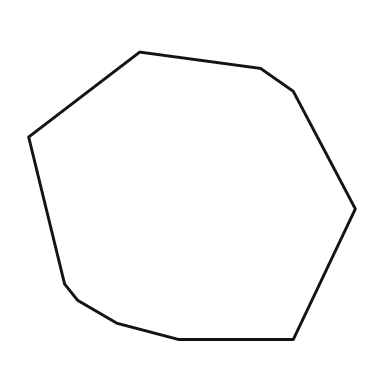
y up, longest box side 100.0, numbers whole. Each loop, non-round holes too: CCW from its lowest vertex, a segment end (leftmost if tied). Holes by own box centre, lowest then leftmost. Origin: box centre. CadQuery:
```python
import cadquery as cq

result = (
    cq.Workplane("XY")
    .moveTo(-4.0, -44.0)
    .lineTo(31.0, -44.0)
    .lineTo(50.0, -4.0)
    .lineTo(31.0, 32.0)
    .lineTo(21.0, 39.0)
    .lineTo(-16.0, 44.0)
    .lineTo(-50.0, 18.0)
    .lineTo(-39.0, -27.0)
    .lineTo(-35.0, -32.0)
    .lineTo(-23.0, -39.0)
    .close()
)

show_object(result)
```